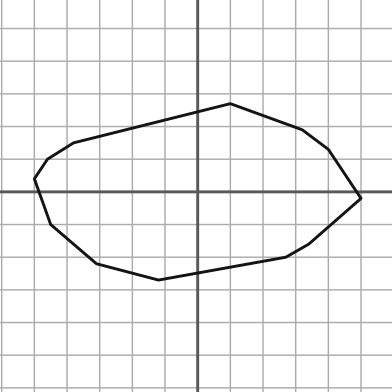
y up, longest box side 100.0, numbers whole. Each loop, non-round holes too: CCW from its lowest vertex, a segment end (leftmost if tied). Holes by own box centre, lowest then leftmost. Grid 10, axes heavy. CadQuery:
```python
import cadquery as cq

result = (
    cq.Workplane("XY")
    .moveTo(-12.0, -27.0)
    .lineTo(27.0, -20.0)
    .lineTo(34.0, -16.0)
    .lineTo(50.0, -2.0)
    .lineTo(40.0, 13.0)
    .lineTo(32.0, 19.0)
    .lineTo(10.0, 27.0)
    .lineTo(-38.0, 15.0)
    .lineTo(-46.0, 10.0)
    .lineTo(-50.0, 4.0)
    .lineTo(-45.0, -10.0)
    .lineTo(-31.0, -22.0)
    .close()
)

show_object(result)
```